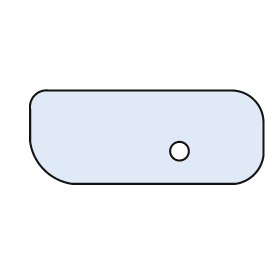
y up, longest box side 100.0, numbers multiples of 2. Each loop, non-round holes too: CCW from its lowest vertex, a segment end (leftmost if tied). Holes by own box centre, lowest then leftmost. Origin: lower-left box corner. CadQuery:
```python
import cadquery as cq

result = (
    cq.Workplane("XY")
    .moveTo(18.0, 0.0)
    .lineTo(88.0, 0.0)
    .threePointArc((96.0, 4.0), (100.0, 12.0))
    .lineTo(100.0, 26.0)
    .threePointArc((96.0, 36.0), (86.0, 40.0))
    .lineTo(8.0, 40.0)
    .threePointArc((2.0, 38.0), (0.0, 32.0))
    .lineTo(0.0, 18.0)
    .threePointArc((6.0, 6.0), (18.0, 0.0))
    .close()
    .moveTo(64.0, 14.0)
    .circle(4.0)
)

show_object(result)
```